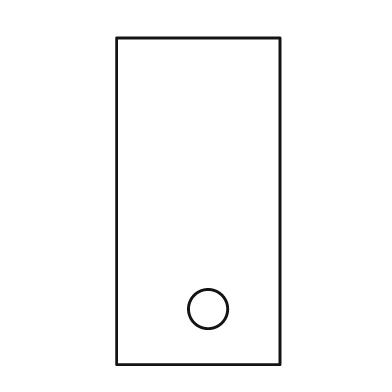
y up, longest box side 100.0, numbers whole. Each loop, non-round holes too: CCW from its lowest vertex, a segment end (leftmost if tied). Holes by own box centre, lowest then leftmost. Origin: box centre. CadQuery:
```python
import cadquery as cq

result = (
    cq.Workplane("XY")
    .moveTo(-25.0, -50.0)
    .lineTo(25.0, -50.0)
    .lineTo(25.0, 50.0)
    .lineTo(-25.0, 50.0)
    .close()
    .moveTo(3.0, -33.0)
    .circle(6.0)
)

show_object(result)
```